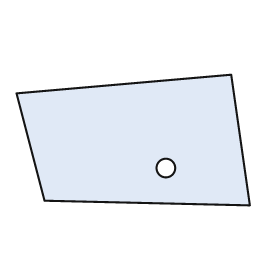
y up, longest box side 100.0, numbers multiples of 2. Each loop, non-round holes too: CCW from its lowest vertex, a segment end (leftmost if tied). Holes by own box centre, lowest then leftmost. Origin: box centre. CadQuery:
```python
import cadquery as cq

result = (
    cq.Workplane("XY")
    .moveTo(50.0, -28.0)
    .lineTo(42.0, 28.0)
    .lineTo(-50.0, 20.0)
    .lineTo(-38.0, -26.0)
    .close()
    .moveTo(14.0, -12.0)
    .circle(4.0)
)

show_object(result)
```